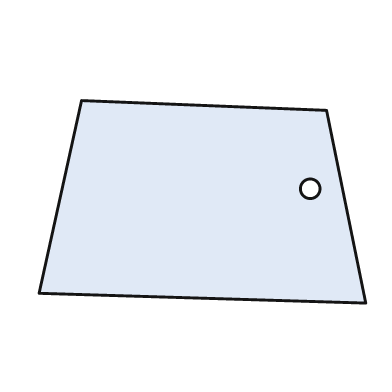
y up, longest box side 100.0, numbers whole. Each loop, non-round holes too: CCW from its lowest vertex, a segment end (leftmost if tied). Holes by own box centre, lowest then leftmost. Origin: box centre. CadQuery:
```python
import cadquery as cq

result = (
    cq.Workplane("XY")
    .moveTo(50.0, -31.0)
    .lineTo(38.0, 28.0)
    .lineTo(-37.0, 31.0)
    .lineTo(-50.0, -28.0)
    .close()
    .moveTo(33.0, 4.0)
    .circle(3.0)
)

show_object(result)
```